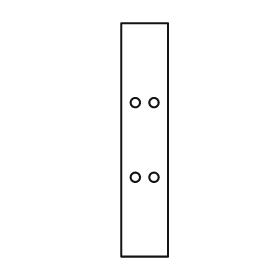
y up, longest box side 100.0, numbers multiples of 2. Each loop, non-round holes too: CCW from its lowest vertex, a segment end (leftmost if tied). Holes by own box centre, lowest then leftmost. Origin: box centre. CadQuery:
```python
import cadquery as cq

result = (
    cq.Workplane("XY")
    .moveTo(-10.0, -50.0)
    .lineTo(10.0, -50.0)
    .lineTo(10.0, 50.0)
    .lineTo(-10.0, 50.0)
    .close()
    .moveTo(-4.0, -16.0)
    .circle(2.0)
    .moveTo(4.0, -16.0)
    .circle(2.0)
    .moveTo(-4.0, 16.0)
    .circle(2.0)
    .moveTo(4.0, 16.0)
    .circle(2.0)
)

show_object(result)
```